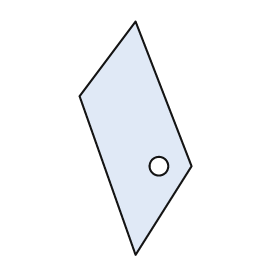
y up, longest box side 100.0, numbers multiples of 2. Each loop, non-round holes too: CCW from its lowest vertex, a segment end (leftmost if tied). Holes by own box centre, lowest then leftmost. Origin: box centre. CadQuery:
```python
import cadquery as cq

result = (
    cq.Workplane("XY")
    .moveTo(0.0, -50.0)
    .lineTo(24.0, -12.0)
    .lineTo(0.0, 50.0)
    .lineTo(-24.0, 18.0)
    .close()
    .moveTo(10.0, -12.0)
    .circle(4.0)
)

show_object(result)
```